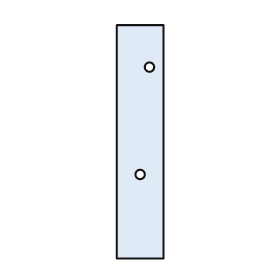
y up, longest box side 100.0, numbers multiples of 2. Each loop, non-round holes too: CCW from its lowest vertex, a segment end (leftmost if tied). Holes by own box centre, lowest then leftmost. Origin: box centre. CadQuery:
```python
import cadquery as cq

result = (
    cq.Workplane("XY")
    .moveTo(-10.0, -50.0)
    .lineTo(10.0, -50.0)
    .lineTo(10.0, 50.0)
    .lineTo(-10.0, 50.0)
    .close()
    .moveTo(0.0, -14.0)
    .circle(2.0)
    .moveTo(4.0, 32.0)
    .circle(2.0)
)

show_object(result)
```